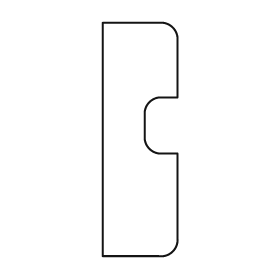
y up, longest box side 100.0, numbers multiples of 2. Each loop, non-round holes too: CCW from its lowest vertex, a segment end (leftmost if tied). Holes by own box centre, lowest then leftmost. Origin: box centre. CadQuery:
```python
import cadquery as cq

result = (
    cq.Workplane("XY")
    .moveTo(-16.0, -50.0)
    .lineTo(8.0, -50.0)
    .threePointArc((14.0, -48.0), (16.0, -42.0))
    .lineTo(16.0, -6.0)
    .lineTo(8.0, -6.0)
    .threePointArc((4.0, -4.0), (2.0, 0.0))
    .lineTo(2.0, 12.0)
    .threePointArc((4.0, 16.0), (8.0, 18.0))
    .lineTo(16.0, 18.0)
    .lineTo(16.0, 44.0)
    .threePointArc((14.0, 48.0), (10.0, 50.0))
    .lineTo(-16.0, 50.0)
    .close()
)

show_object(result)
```